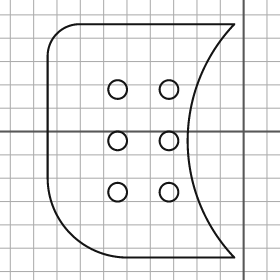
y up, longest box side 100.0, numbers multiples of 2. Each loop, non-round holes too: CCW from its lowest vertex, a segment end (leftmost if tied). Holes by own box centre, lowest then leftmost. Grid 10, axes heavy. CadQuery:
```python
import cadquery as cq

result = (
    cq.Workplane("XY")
    .moveTo(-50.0, -54.0)
    .lineTo(-4.0, -54.0)
    .threePointArc((-24.0, -4.0), (-4.0, 46.0))
    .lineTo(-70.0, 46.0)
    .threePointArc((-80.0, 42.0), (-84.0, 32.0))
    .lineTo(-84.0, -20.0)
    .threePointArc((-74.0, -44.0), (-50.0, -54.0))
    .close()
    .moveTo(-54.0, -26.0)
    .circle(4.0)
    .moveTo(-32.0, -26.0)
    .circle(4.0)
    .moveTo(-54.0, -4.0)
    .circle(4.0)
    .moveTo(-32.0, -4.0)
    .circle(4.0)
    .moveTo(-54.0, 18.0)
    .circle(4.0)
    .moveTo(-32.0, 18.0)
    .circle(4.0)
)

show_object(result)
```